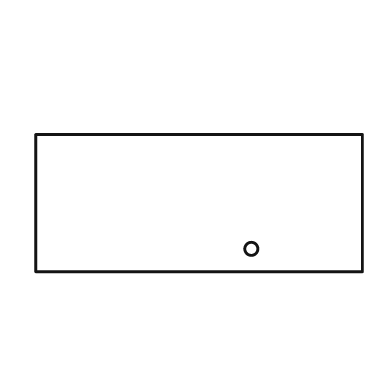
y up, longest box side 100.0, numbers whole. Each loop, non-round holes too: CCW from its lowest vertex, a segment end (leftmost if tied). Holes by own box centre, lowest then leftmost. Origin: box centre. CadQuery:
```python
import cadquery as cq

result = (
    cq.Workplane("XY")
    .moveTo(-50.0, -21.0)
    .lineTo(50.0, -21.0)
    .lineTo(50.0, 21.0)
    .lineTo(-50.0, 21.0)
    .close()
    .moveTo(16.0, -14.0)
    .circle(2.0)
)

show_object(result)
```